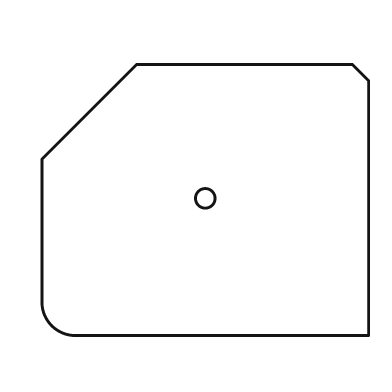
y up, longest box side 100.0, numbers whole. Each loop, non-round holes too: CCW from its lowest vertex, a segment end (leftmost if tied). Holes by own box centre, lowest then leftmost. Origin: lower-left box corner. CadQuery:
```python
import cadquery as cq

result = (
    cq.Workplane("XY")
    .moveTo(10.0, 0.0)
    .lineTo(100.0, 0.0)
    .lineTo(100.0, 78.0)
    .lineTo(95.0, 83.0)
    .lineTo(29.0, 83.0)
    .lineTo(0.0, 54.0)
    .lineTo(0.0, 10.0)
    .threePointArc((3.0, 3.0), (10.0, 0.0))
    .close()
    .moveTo(50.0, 42.0)
    .circle(3.0)
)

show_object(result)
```